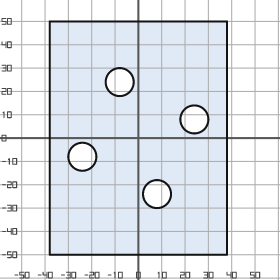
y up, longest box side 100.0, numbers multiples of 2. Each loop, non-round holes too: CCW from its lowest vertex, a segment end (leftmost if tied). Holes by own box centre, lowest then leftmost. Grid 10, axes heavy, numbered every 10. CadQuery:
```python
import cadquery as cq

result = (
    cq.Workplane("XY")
    .moveTo(-38.0, -50.0)
    .lineTo(38.0, -50.0)
    .lineTo(38.0, 50.0)
    .lineTo(-38.0, 50.0)
    .close()
    .moveTo(8.0, -24.0)
    .circle(6.0)
    .moveTo(-24.0, -8.0)
    .circle(6.0)
    .moveTo(24.0, 8.0)
    .circle(6.0)
    .moveTo(-8.0, 24.0)
    .circle(6.0)
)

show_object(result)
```